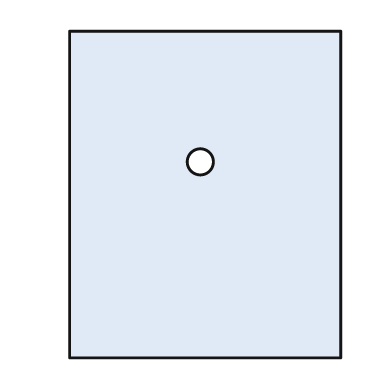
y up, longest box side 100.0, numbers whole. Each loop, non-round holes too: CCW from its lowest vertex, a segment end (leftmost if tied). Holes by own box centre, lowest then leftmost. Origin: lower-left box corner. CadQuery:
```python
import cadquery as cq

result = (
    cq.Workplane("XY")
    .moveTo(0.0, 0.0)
    .lineTo(83.0, 0.0)
    .lineTo(83.0, 100.0)
    .lineTo(0.0, 100.0)
    .close()
    .moveTo(40.0, 60.0)
    .circle(4.0)
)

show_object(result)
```